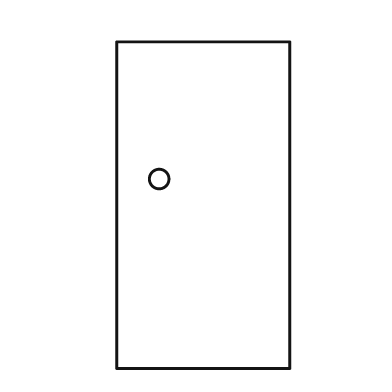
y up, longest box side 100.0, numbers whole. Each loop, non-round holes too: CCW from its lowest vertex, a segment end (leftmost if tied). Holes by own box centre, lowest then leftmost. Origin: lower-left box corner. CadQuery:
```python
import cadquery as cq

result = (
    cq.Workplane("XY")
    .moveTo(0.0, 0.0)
    .lineTo(53.0, 0.0)
    .lineTo(53.0, 100.0)
    .lineTo(0.0, 100.0)
    .close()
    .moveTo(13.0, 58.0)
    .circle(3.0)
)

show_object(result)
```